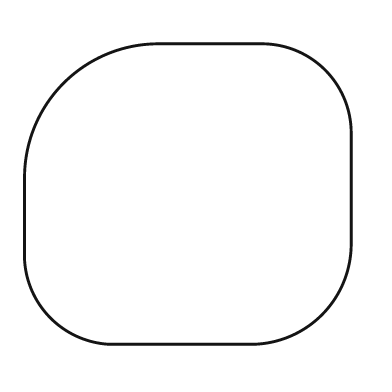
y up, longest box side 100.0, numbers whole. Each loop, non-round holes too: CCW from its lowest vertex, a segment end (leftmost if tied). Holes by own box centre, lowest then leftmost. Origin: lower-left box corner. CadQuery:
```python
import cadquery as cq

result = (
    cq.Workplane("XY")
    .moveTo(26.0, 0.0)
    .lineTo(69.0, 0.0)
    .threePointArc((91.0, 9.0), (100.0, 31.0))
    .lineTo(100.0, 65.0)
    .threePointArc((92.0, 84.0), (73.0, 92.0))
    .lineTo(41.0, 92.0)
    .threePointArc((12.0, 80.0), (0.0, 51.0))
    .lineTo(0.0, 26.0)
    .threePointArc((8.0, 8.0), (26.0, 0.0))
    .close()
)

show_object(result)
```